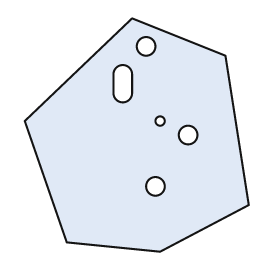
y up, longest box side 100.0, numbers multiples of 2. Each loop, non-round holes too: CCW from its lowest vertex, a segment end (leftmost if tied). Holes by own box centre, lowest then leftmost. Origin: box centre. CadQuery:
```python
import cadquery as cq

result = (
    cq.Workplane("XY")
    .moveTo(10.0, -50.0)
    .lineTo(48.0, -30.0)
    .lineTo(38.0, 34.0)
    .lineTo(-2.0, 50.0)
    .lineTo(-48.0, 6.0)
    .lineTo(-30.0, -46.0)
    .close()
    .moveTo(8.0, -22.0)
    .circle(4.0)
    .moveTo(22.0, 0.0)
    .circle(4.0)
    .moveTo(10.0, 6.0)
    .circle(2.0)
    .moveTo(-10.0, 18.0)
    .threePointArc((-6.0, 14.0), (-2.0, 18.0))
    .lineTo(-2.0, 26.0)
    .threePointArc((-6.0, 30.0), (-10.0, 26.0))
    .close()
    .moveTo(4.0, 38.0)
    .circle(4.0)
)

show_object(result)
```